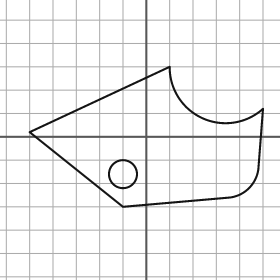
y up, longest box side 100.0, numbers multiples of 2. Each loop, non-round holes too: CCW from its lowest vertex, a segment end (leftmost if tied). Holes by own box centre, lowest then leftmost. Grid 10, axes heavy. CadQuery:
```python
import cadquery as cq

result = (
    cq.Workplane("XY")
    .moveTo(-10.0, -30.0)
    .lineTo(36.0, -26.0)
    .threePointArc((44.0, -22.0), (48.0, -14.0))
    .lineTo(50.0, 12.0)
    .threePointArc((24.0, 8.0), (10.0, 30.0))
    .lineTo(-50.0, 2.0)
    .close()
    .moveTo(-10.0, -16.0)
    .circle(6.0)
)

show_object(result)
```